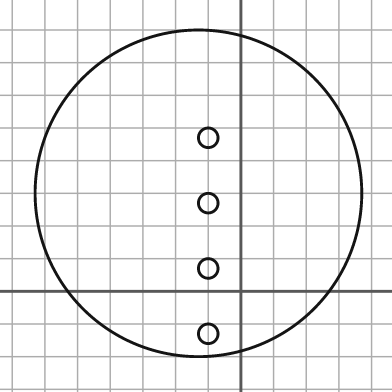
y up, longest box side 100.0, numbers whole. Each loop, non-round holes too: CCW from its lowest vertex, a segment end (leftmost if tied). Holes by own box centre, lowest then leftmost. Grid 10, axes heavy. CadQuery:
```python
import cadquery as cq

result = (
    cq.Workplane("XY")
    .moveTo(-13.0, 30.0)
    .circle(50.0)
    .moveTo(-10.0, -13.0)
    .circle(3.0)
    .moveTo(-10.0, 7.0)
    .circle(3.0)
    .moveTo(-10.0, 27.0)
    .circle(3.0)
    .moveTo(-10.0, 47.0)
    .circle(3.0)
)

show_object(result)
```